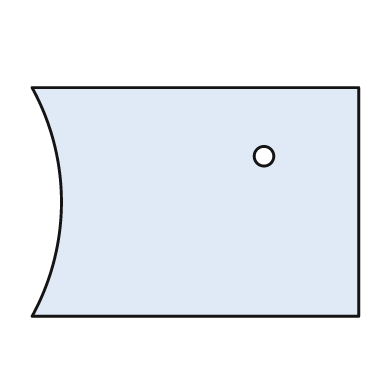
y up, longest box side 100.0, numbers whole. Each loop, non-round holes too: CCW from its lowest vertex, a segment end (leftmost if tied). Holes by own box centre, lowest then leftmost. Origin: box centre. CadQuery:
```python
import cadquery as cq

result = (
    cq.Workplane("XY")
    .moveTo(-50.0, -35.0)
    .lineTo(50.0, -35.0)
    .lineTo(50.0, 35.0)
    .lineTo(-50.0, 35.0)
    .threePointArc((-41.0, 0.0), (-50.0, -35.0))
    .close()
    .moveTo(21.0, 14.0)
    .circle(3.0)
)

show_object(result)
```